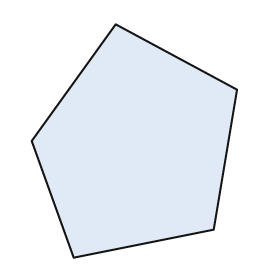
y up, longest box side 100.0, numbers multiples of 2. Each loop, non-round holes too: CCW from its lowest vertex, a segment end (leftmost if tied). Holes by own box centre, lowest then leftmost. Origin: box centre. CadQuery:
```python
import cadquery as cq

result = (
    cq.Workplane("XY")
    .moveTo(-26.0, -50.0)
    .lineTo(34.0, -38.0)
    .lineTo(44.0, 22.0)
    .lineTo(-8.0, 50.0)
    .lineTo(-44.0, 0.0)
    .close()
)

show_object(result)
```